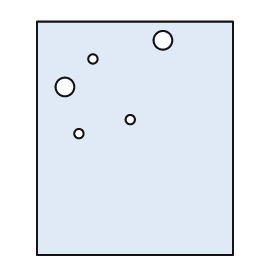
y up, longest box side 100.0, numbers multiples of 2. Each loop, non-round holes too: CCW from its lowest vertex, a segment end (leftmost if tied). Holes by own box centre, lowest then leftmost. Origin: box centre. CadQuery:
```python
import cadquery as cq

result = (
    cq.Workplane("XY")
    .moveTo(-42.0, -50.0)
    .lineTo(42.0, -50.0)
    .lineTo(42.0, 50.0)
    .lineTo(-42.0, 50.0)
    .close()
    .moveTo(-24.0, 2.0)
    .circle(2.0)
    .moveTo(-2.0, 8.0)
    .circle(2.0)
    .moveTo(-30.0, 22.0)
    .circle(4.0)
    .moveTo(-18.0, 34.0)
    .circle(2.0)
    .moveTo(12.0, 42.0)
    .circle(4.0)
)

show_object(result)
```